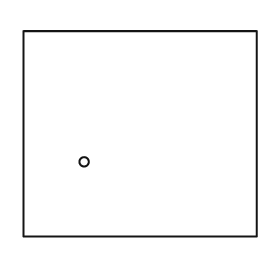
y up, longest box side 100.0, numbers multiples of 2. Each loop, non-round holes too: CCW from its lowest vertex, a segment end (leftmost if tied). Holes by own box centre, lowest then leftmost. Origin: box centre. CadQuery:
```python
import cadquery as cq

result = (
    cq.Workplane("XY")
    .moveTo(-50.0, -44.0)
    .lineTo(50.0, -44.0)
    .lineTo(50.0, 44.0)
    .lineTo(-50.0, 44.0)
    .close()
    .moveTo(-24.0, -12.0)
    .circle(2.0)
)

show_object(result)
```